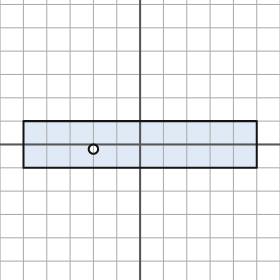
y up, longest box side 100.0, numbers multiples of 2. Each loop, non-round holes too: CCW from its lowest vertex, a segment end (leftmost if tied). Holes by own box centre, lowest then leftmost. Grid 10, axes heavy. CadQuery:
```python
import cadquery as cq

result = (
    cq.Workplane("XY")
    .moveTo(-50.0, -10.0)
    .lineTo(50.0, -10.0)
    .lineTo(50.0, 10.0)
    .lineTo(-50.0, 10.0)
    .close()
    .moveTo(-20.0, -2.0)
    .circle(2.0)
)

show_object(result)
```